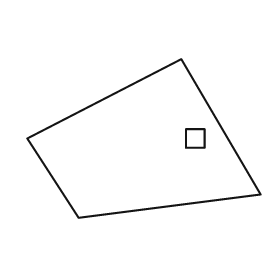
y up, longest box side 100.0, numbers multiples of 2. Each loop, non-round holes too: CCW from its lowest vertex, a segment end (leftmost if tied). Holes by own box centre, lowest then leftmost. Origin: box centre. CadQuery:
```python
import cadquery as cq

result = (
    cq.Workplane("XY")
    .moveTo(-28.0, -34.0)
    .lineTo(50.0, -24.0)
    .lineTo(16.0, 34.0)
    .lineTo(-50.0, 0.0)
    .close()
    .moveTo(18.0, -4.0)
    .lineTo(26.0, -4.0)
    .lineTo(26.0, 4.0)
    .lineTo(18.0, 4.0)
    .close()
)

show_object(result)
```